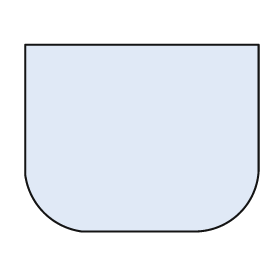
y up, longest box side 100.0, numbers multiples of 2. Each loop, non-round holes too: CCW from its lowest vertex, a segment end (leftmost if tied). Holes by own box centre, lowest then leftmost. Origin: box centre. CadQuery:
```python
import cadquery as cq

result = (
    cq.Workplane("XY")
    .moveTo(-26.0, -40.0)
    .lineTo(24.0, -40.0)
    .threePointArc((42.0, -32.0), (50.0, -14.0))
    .lineTo(50.0, 40.0)
    .lineTo(-50.0, 40.0)
    .lineTo(-50.0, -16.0)
    .threePointArc((-42.0, -32.0), (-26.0, -40.0))
    .close()
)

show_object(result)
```